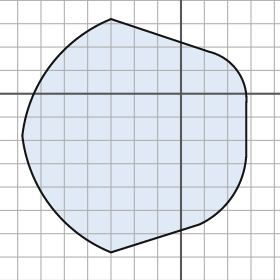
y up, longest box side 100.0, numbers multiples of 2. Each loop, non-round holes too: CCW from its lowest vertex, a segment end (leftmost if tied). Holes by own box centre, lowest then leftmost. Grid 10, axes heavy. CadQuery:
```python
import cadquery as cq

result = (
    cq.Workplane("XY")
    .moveTo(-30.0, -68.0)
    .lineTo(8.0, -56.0)
    .threePointArc((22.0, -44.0), (28.0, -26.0))
    .lineTo(28.0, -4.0)
    .threePointArc((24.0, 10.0), (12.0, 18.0))
    .lineTo(-30.0, 32.0)
    .threePointArc((-56.0, 12.0), (-68.0, -18.0))
    .threePointArc((-56.0, -48.0), (-30.0, -68.0))
    .close()
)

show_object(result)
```